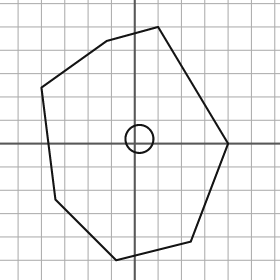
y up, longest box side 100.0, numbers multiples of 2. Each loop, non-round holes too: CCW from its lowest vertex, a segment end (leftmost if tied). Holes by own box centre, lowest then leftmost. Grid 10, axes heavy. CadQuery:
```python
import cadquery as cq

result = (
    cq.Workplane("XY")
    .moveTo(-8.0, -50.0)
    .lineTo(24.0, -42.0)
    .lineTo(40.0, 0.0)
    .lineTo(10.0, 50.0)
    .lineTo(-12.0, 44.0)
    .lineTo(-40.0, 24.0)
    .lineTo(-34.0, -24.0)
    .close()
    .moveTo(2.0, 2.0)
    .circle(6.0)
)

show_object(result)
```